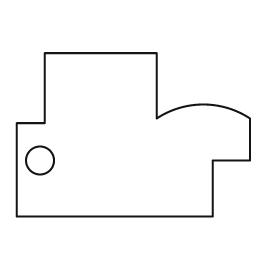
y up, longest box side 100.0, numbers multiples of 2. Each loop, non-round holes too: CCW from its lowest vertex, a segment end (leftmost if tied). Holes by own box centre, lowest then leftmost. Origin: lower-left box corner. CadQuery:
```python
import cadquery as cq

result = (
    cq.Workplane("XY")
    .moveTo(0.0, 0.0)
    .lineTo(84.0, 0.0)
    .lineTo(84.0, 24.0)
    .lineTo(100.0, 24.0)
    .lineTo(100.0, 42.0)
    .threePointArc((80.0, 48.0), (60.0, 42.0))
    .lineTo(60.0, 70.0)
    .lineTo(12.0, 70.0)
    .lineTo(12.0, 40.0)
    .lineTo(0.0, 40.0)
    .close()
    .moveTo(10.0, 24.0)
    .circle(6.0)
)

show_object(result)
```